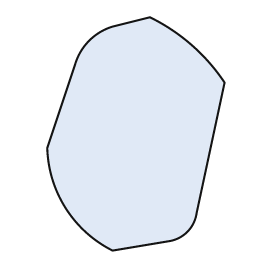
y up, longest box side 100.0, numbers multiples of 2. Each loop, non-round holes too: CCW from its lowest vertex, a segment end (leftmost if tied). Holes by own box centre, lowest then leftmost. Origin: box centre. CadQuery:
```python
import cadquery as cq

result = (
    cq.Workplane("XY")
    .moveTo(-10.0, -50.0)
    .lineTo(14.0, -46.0)
    .threePointArc((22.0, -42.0), (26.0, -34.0))
    .lineTo(38.0, 22.0)
    .threePointArc((24.0, 38.0), (6.0, 50.0))
    .lineTo(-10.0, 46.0)
    .threePointArc((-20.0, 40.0), (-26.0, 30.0))
    .lineTo(-38.0, -6.0)
    .threePointArc((-30.0, -32.0), (-10.0, -50.0))
    .close()
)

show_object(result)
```